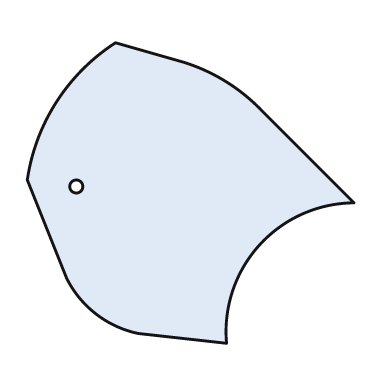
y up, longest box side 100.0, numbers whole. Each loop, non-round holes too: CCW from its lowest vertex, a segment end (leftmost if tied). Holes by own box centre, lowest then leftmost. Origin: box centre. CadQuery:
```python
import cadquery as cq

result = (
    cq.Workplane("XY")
    .moveTo(11.0, -46.0)
    .threePointArc((21.0, -16.0), (50.0, -3.0))
    .lineTo(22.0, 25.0)
    .threePointArc((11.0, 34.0), (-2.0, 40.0))
    .lineTo(-23.0, 46.0)
    .threePointArc((-41.0, 28.0), (-50.0, 4.0))
    .lineTo(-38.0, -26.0)
    .threePointArc((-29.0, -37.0), (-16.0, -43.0))
    .close()
    .moveTo(-35.0, 2.0)
    .circle(2.0)
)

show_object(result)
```